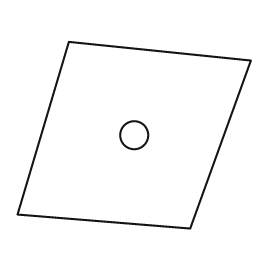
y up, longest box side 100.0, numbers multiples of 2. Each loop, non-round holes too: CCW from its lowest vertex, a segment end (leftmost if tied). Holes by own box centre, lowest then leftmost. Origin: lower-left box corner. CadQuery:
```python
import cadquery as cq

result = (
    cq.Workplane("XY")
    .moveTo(74.0, 0.0)
    .lineTo(100.0, 72.0)
    .lineTo(22.0, 80.0)
    .lineTo(0.0, 6.0)
    .close()
    .moveTo(50.0, 40.0)
    .circle(6.0)
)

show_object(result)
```